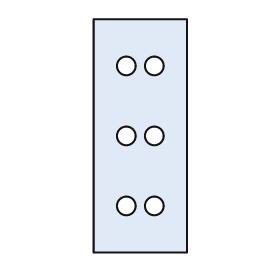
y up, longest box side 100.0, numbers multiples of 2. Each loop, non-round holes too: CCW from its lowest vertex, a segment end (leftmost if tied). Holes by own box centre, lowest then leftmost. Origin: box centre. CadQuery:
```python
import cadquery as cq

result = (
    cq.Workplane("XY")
    .moveTo(-20.0, -50.0)
    .lineTo(20.0, -50.0)
    .lineTo(20.0, 50.0)
    .lineTo(-20.0, 50.0)
    .close()
    .moveTo(-6.0, -30.0)
    .circle(4.0)
    .moveTo(6.0, -30.0)
    .circle(4.0)
    .moveTo(-6.0, 0.0)
    .circle(4.0)
    .moveTo(6.0, 0.0)
    .circle(4.0)
    .moveTo(-6.0, 30.0)
    .circle(4.0)
    .moveTo(6.0, 30.0)
    .circle(4.0)
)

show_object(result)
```